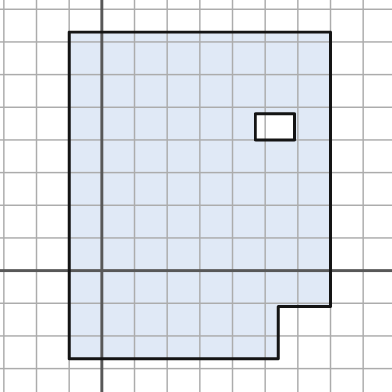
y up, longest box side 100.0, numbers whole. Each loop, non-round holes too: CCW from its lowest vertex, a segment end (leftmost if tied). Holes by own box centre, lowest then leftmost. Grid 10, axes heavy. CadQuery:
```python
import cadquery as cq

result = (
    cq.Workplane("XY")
    .moveTo(-10.0, -27.0)
    .lineTo(54.0, -27.0)
    .lineTo(54.0, -11.0)
    .lineTo(70.0, -11.0)
    .lineTo(70.0, 73.0)
    .lineTo(-10.0, 73.0)
    .close()
    .moveTo(47.0, 40.0)
    .lineTo(59.0, 40.0)
    .lineTo(59.0, 48.0)
    .lineTo(47.0, 48.0)
    .close()
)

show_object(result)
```